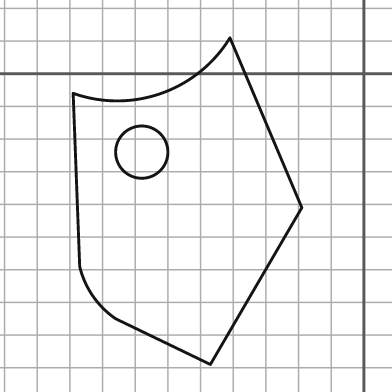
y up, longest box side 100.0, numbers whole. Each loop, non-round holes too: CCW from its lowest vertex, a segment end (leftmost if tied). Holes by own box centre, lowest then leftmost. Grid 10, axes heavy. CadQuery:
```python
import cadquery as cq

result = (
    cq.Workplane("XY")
    .moveTo(-47.0, -89.0)
    .lineTo(-19.0, -41.0)
    .lineTo(-41.0, 11.0)
    .threePointArc((-62.0, -6.0), (-89.0, -6.0))
    .lineTo(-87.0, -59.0)
    .threePointArc((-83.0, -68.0), (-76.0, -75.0))
    .close()
    .moveTo(-68.0, -24.0)
    .circle(8.0)
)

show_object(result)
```